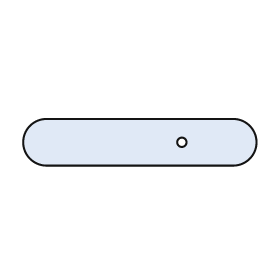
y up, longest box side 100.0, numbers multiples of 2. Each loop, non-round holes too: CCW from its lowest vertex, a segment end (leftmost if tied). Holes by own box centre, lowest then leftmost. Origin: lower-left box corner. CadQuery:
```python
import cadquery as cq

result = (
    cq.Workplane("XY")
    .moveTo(10.0, 0.0)
    .lineTo(90.0, 0.0)
    .threePointArc((100.0, 10.0), (90.0, 20.0))
    .lineTo(10.0, 20.0)
    .threePointArc((0.0, 10.0), (10.0, 0.0))
    .close()
    .moveTo(68.0, 10.0)
    .circle(2.0)
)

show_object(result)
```